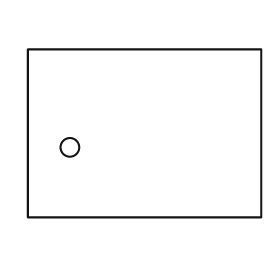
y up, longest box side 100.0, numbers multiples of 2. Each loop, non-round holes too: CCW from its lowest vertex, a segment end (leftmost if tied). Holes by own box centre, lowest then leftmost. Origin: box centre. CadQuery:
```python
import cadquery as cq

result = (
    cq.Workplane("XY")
    .moveTo(-50.0, -36.0)
    .lineTo(50.0, -36.0)
    .lineTo(50.0, 36.0)
    .lineTo(-50.0, 36.0)
    .close()
    .moveTo(-32.0, -6.0)
    .circle(4.0)
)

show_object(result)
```